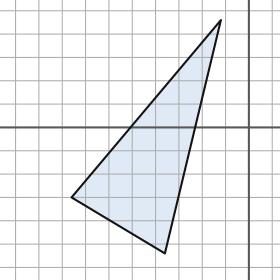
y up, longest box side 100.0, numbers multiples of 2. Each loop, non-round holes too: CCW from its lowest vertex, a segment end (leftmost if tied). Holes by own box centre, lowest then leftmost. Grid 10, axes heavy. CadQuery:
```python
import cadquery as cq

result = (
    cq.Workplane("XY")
    .moveTo(-36.0, -54.0)
    .lineTo(-12.0, 46.0)
    .lineTo(-76.0, -30.0)
    .close()
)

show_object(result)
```